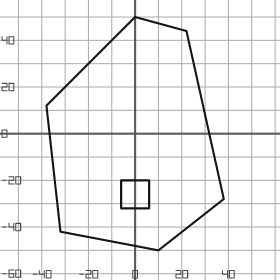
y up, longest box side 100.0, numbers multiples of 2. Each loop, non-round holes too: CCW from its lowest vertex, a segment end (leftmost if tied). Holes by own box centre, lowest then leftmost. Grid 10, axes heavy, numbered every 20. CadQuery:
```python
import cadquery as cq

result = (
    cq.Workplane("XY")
    .moveTo(10.0, -50.0)
    .lineTo(38.0, -28.0)
    .lineTo(22.0, 44.0)
    .lineTo(0.0, 50.0)
    .lineTo(-38.0, 12.0)
    .lineTo(-32.0, -42.0)
    .close()
    .moveTo(-6.0, -32.0)
    .lineTo(6.0, -32.0)
    .lineTo(6.0, -20.0)
    .lineTo(-6.0, -20.0)
    .close()
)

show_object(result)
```